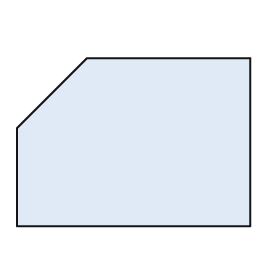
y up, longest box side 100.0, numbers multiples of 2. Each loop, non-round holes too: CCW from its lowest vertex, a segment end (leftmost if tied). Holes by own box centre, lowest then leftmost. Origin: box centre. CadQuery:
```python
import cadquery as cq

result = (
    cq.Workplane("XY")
    .moveTo(-50.0, -36.0)
    .lineTo(50.0, -36.0)
    .lineTo(50.0, 36.0)
    .lineTo(-20.0, 36.0)
    .lineTo(-50.0, 6.0)
    .close()
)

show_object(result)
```